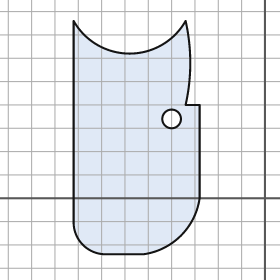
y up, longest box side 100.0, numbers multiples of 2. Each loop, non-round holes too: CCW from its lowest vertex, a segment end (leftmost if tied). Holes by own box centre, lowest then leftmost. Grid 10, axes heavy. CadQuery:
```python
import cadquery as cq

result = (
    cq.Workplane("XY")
    .moveTo(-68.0, -24.0)
    .lineTo(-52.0, -24.0)
    .threePointArc((-36.0, -16.0), (-28.0, 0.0))
    .lineTo(-28.0, 40.0)
    .lineTo(-34.0, 40.0)
    .threePointArc((-32.0, 58.0), (-34.0, 76.0))
    .threePointArc((-58.0, 62.0), (-82.0, 76.0))
    .lineTo(-82.0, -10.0)
    .threePointArc((-78.0, -20.0), (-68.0, -24.0))
    .close()
    .moveTo(-40.0, 34.0)
    .circle(4.0)
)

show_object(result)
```